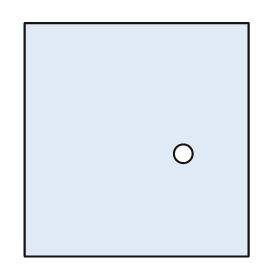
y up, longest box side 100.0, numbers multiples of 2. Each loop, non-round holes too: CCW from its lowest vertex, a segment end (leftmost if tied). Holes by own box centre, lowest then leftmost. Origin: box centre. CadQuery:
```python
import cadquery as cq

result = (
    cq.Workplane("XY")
    .moveTo(-48.0, -50.0)
    .lineTo(48.0, -50.0)
    .lineTo(48.0, 50.0)
    .lineTo(-48.0, 50.0)
    .close()
    .moveTo(20.0, -6.0)
    .circle(4.0)
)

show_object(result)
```